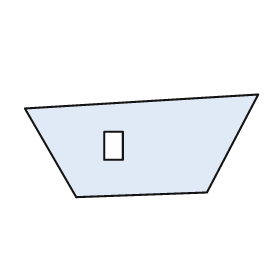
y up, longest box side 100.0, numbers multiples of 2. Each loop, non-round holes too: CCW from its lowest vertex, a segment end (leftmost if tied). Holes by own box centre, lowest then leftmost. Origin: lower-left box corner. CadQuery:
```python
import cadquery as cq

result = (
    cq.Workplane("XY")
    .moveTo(22.0, 0.0)
    .lineTo(78.0, 2.0)
    .lineTo(100.0, 44.0)
    .lineTo(0.0, 38.0)
    .close()
    .moveTo(34.0, 16.0)
    .lineTo(42.0, 16.0)
    .lineTo(42.0, 28.0)
    .lineTo(34.0, 28.0)
    .close()
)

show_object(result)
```